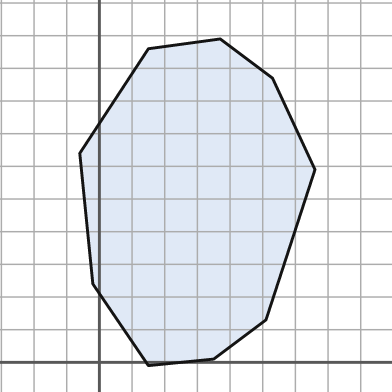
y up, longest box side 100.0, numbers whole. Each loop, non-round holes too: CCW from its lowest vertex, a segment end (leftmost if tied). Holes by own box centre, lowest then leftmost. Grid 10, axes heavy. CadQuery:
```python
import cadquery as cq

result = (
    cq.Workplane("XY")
    .moveTo(15.0, -1.0)
    .lineTo(35.0, 1.0)
    .lineTo(51.0, 13.0)
    .lineTo(66.0, 59.0)
    .lineTo(53.0, 87.0)
    .lineTo(37.0, 99.0)
    .lineTo(15.0, 96.0)
    .lineTo(-6.0, 64.0)
    .lineTo(-2.0, 24.0)
    .close()
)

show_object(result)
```